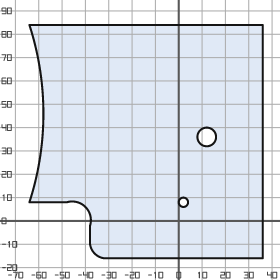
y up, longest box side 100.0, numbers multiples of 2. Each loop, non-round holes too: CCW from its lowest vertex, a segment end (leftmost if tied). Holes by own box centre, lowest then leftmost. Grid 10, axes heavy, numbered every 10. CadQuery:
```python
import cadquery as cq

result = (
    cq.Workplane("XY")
    .moveTo(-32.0, -16.0)
    .lineTo(36.0, -16.0)
    .lineTo(36.0, 84.0)
    .lineTo(-64.0, 84.0)
    .threePointArc((-58.0, 46.0), (-64.0, 8.0))
    .lineTo(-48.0, 8.0)
    .threePointArc((-40.0, 6.0), (-38.0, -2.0))
    .lineTo(-38.0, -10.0)
    .threePointArc((-36.0, -14.0), (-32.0, -16.0))
    .close()
    .moveTo(2.0, 8.0)
    .circle(2.0)
    .moveTo(12.0, 36.0)
    .circle(4.0)
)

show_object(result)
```